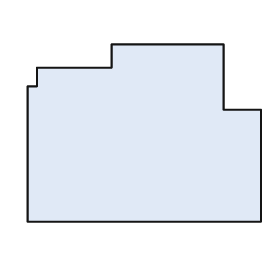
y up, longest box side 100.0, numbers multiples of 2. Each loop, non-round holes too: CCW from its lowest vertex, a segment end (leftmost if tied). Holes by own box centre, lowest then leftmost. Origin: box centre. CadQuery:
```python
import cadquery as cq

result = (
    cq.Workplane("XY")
    .moveTo(-50.0, -38.0)
    .lineTo(50.0, -38.0)
    .lineTo(50.0, 10.0)
    .lineTo(34.0, 10.0)
    .lineTo(34.0, 38.0)
    .lineTo(-14.0, 38.0)
    .lineTo(-14.0, 28.0)
    .lineTo(-46.0, 28.0)
    .lineTo(-46.0, 20.0)
    .lineTo(-50.0, 20.0)
    .close()
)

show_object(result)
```